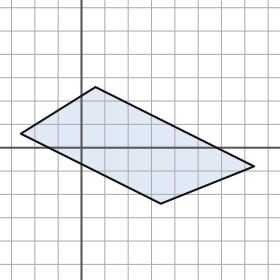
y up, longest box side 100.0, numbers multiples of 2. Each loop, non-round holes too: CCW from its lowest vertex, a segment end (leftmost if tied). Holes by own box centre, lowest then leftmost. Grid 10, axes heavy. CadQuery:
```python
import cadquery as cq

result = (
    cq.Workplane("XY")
    .moveTo(34.0, -24.0)
    .lineTo(74.0, -8.0)
    .lineTo(6.0, 26.0)
    .lineTo(-26.0, 6.0)
    .close()
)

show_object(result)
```